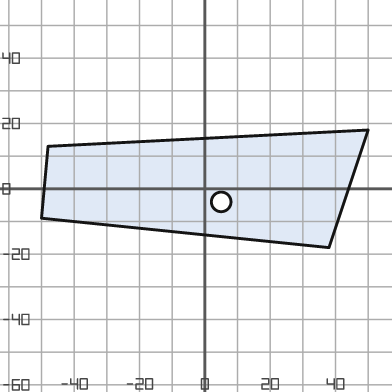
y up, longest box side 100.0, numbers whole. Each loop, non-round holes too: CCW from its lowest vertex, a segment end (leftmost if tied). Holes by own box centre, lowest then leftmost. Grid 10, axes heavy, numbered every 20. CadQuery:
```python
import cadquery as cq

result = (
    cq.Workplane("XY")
    .moveTo(38.0, -18.0)
    .lineTo(50.0, 18.0)
    .lineTo(-48.0, 13.0)
    .lineTo(-50.0, -9.0)
    .close()
    .moveTo(5.0, -4.0)
    .circle(3.0)
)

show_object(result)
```